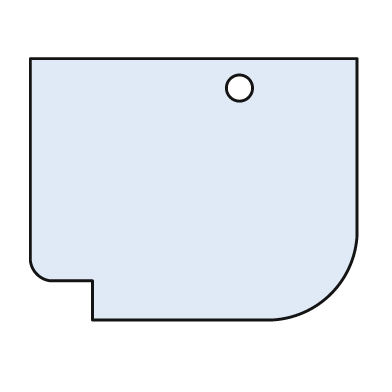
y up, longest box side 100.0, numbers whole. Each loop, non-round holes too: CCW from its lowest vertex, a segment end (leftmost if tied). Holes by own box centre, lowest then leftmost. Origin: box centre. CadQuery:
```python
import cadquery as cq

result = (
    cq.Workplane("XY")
    .moveTo(-31.0, -40.0)
    .lineTo(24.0, -40.0)
    .threePointArc((42.0, -32.0), (50.0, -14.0))
    .lineTo(50.0, 40.0)
    .lineTo(-50.0, 40.0)
    .lineTo(-50.0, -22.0)
    .threePointArc((-48.0, -26.0), (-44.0, -28.0))
    .lineTo(-31.0, -28.0)
    .close()
    .moveTo(14.0, 31.0)
    .circle(4.0)
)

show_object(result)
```